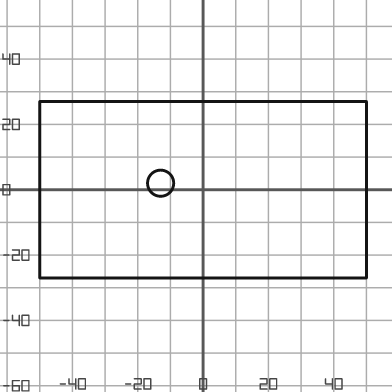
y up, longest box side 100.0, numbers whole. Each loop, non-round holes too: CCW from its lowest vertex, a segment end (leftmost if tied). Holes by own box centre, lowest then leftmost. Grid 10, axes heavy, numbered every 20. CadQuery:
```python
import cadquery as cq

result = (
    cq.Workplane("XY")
    .moveTo(-50.0, -27.0)
    .lineTo(50.0, -27.0)
    .lineTo(50.0, 27.0)
    .lineTo(-50.0, 27.0)
    .close()
    .moveTo(-13.0, 2.0)
    .circle(4.0)
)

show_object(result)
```